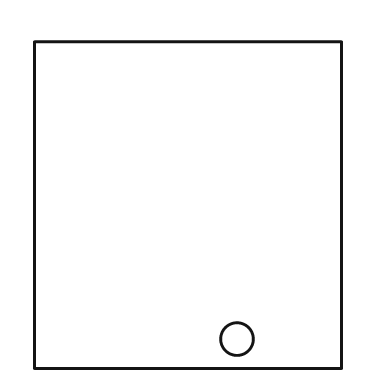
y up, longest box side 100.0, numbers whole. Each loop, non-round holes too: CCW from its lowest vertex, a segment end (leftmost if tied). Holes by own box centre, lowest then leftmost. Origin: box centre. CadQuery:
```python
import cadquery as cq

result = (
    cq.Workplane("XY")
    .moveTo(-47.0, -50.0)
    .lineTo(47.0, -50.0)
    .lineTo(47.0, 50.0)
    .lineTo(-47.0, 50.0)
    .close()
    .moveTo(15.0, -41.0)
    .circle(5.0)
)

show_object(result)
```